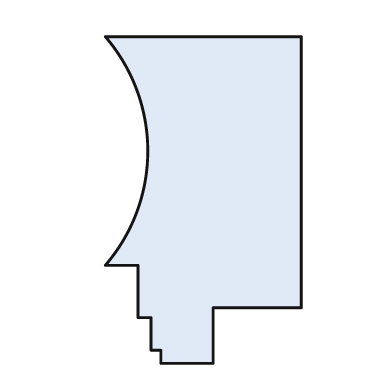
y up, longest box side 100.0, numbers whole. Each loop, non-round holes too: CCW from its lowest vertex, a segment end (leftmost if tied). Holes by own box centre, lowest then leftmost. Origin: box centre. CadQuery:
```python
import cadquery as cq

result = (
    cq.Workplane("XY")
    .moveTo(-13.0, -50.0)
    .lineTo(3.0, -50.0)
    .lineTo(3.0, -33.0)
    .lineTo(30.0, -33.0)
    .lineTo(30.0, 50.0)
    .lineTo(-30.0, 50.0)
    .threePointArc((-17.0, 15.0), (-30.0, -20.0))
    .lineTo(-20.0, -20.0)
    .lineTo(-20.0, -36.0)
    .lineTo(-16.0, -36.0)
    .lineTo(-16.0, -46.0)
    .lineTo(-13.0, -46.0)
    .close()
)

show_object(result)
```